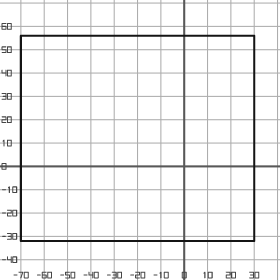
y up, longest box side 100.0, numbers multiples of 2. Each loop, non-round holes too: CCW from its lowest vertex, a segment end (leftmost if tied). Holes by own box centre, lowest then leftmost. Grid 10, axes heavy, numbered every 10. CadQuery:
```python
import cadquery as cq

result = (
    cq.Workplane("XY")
    .moveTo(-70.0, -32.0)
    .lineTo(30.0, -32.0)
    .lineTo(30.0, 56.0)
    .lineTo(-70.0, 56.0)
    .close()
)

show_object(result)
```